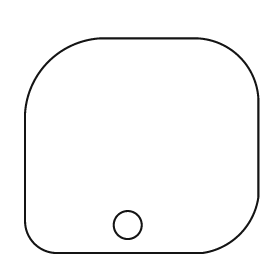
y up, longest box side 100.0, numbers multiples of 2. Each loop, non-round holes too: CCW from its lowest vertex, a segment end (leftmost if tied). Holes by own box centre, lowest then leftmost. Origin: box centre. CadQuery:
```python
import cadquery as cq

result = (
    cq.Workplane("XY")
    .moveTo(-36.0, -46.0)
    .lineTo(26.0, -46.0)
    .threePointArc((42.0, -38.0), (50.0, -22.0))
    .lineTo(50.0, 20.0)
    .threePointArc((42.0, 38.0), (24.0, 46.0))
    .lineTo(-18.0, 46.0)
    .threePointArc((-40.0, 36.0), (-50.0, 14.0))
    .lineTo(-50.0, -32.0)
    .threePointArc((-46.0, -42.0), (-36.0, -46.0))
    .close()
    .moveTo(-6.0, -34.0)
    .circle(6.0)
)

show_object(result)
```